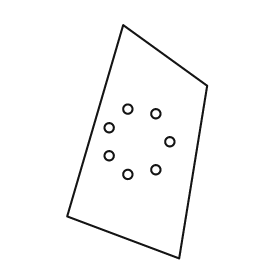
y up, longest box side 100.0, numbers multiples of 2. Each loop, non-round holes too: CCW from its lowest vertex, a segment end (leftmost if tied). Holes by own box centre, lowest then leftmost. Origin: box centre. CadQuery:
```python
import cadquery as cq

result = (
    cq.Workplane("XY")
    .moveTo(18.0, -50.0)
    .lineTo(30.0, 24.0)
    .lineTo(-6.0, 50.0)
    .lineTo(-30.0, -32.0)
    .close()
    .moveTo(-4.0, -14.0)
    .circle(2.0)
    .moveTo(8.0, -12.0)
    .circle(2.0)
    .moveTo(-12.0, -6.0)
    .circle(2.0)
    .moveTo(14.0, 0.0)
    .circle(2.0)
    .moveTo(-12.0, 6.0)
    .circle(2.0)
    .moveTo(8.0, 12.0)
    .circle(2.0)
    .moveTo(-4.0, 14.0)
    .circle(2.0)
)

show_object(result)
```